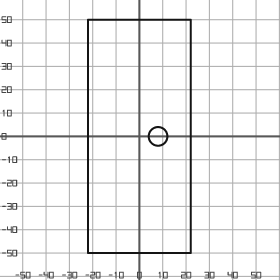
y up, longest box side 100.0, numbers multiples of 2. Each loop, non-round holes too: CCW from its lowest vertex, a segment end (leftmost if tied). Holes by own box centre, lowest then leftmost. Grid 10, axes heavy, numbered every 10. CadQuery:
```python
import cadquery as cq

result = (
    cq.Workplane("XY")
    .moveTo(-22.0, -50.0)
    .lineTo(22.0, -50.0)
    .lineTo(22.0, 50.0)
    .lineTo(-22.0, 50.0)
    .close()
    .moveTo(8.0, 0.0)
    .circle(4.0)
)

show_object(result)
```